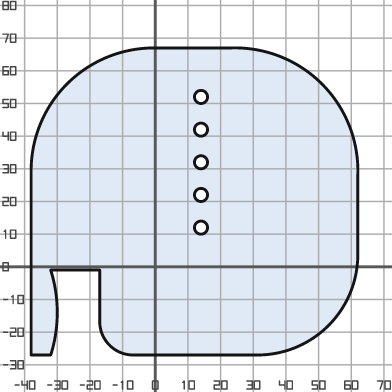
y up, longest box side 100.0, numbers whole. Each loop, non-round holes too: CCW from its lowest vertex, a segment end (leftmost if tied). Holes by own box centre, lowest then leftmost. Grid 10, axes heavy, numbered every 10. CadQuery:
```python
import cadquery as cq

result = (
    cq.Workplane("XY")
    .moveTo(-38.0, -27.0)
    .lineTo(-32.0, -27.0)
    .threePointArc((-30.0, -14.0), (-32.0, -1.0))
    .lineTo(-17.0, -1.0)
    .lineTo(-17.0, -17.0)
    .threePointArc((-14.0, -24.0), (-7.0, -27.0))
    .lineTo(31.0, -27.0)
    .threePointArc((53.0, -18.0), (62.0, 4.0))
    .lineTo(62.0, 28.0)
    .threePointArc((51.0, 56.0), (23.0, 67.0))
    .lineTo(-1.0, 67.0)
    .threePointArc((-27.0, 56.0), (-38.0, 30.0))
    .close()
    .moveTo(14.0, 12.0)
    .circle(2.0)
    .moveTo(14.0, 22.0)
    .circle(2.0)
    .moveTo(14.0, 32.0)
    .circle(2.0)
    .moveTo(14.0, 42.0)
    .circle(2.0)
    .moveTo(14.0, 52.0)
    .circle(2.0)
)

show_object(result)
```